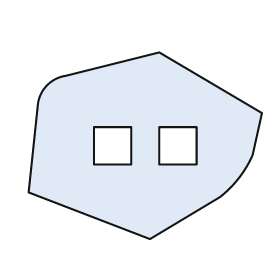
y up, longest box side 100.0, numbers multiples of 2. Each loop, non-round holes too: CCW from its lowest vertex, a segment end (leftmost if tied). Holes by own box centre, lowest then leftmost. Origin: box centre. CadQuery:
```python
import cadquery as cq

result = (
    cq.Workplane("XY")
    .moveTo(2.0, -40.0)
    .lineTo(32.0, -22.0)
    .threePointArc((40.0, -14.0), (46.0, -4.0))
    .lineTo(50.0, 14.0)
    .lineTo(6.0, 40.0)
    .lineTo(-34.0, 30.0)
    .threePointArc((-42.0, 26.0), (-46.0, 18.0))
    .lineTo(-50.0, -20.0)
    .close()
    .moveTo(-22.0, -8.0)
    .lineTo(-6.0, -8.0)
    .lineTo(-6.0, 8.0)
    .lineTo(-22.0, 8.0)
    .close()
    .moveTo(6.0, -8.0)
    .lineTo(22.0, -8.0)
    .lineTo(22.0, 8.0)
    .lineTo(6.0, 8.0)
    .close()
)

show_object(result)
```